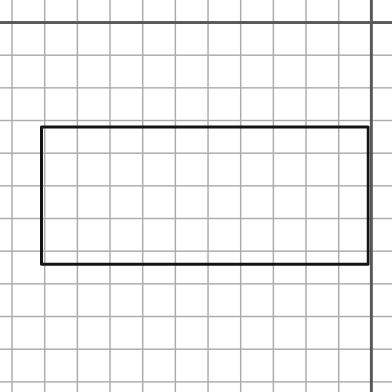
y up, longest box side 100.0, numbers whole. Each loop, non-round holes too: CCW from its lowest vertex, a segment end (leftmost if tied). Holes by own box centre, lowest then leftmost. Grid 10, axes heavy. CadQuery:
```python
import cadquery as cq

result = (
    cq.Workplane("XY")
    .moveTo(-101.0, -74.0)
    .lineTo(-1.0, -74.0)
    .lineTo(-1.0, -32.0)
    .lineTo(-101.0, -32.0)
    .close()
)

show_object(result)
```